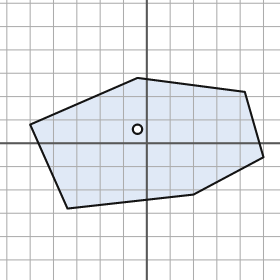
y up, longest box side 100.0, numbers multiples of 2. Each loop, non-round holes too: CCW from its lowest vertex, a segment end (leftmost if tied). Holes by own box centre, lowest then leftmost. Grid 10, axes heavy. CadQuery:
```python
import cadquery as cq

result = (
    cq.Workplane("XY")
    .moveTo(-34.0, -28.0)
    .lineTo(20.0, -22.0)
    .lineTo(50.0, -6.0)
    .lineTo(42.0, 22.0)
    .lineTo(-4.0, 28.0)
    .lineTo(-50.0, 8.0)
    .close()
    .moveTo(-4.0, 6.0)
    .circle(2.0)
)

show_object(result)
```